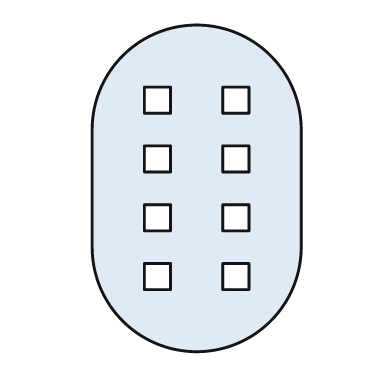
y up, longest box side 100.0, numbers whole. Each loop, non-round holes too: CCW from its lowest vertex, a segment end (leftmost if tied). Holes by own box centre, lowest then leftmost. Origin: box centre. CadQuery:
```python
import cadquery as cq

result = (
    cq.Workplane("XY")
    .moveTo(-32.0, -18.0)
    .threePointArc((0.0, -50.0), (32.0, -18.0))
    .lineTo(32.0, 18.0)
    .threePointArc((0.0, 50.0), (-32.0, 18.0))
    .close()
    .moveTo(-16.0, -31.0)
    .lineTo(-8.0, -31.0)
    .lineTo(-8.0, -23.0)
    .lineTo(-16.0, -23.0)
    .close()
    .moveTo(8.0, -31.0)
    .lineTo(16.0, -31.0)
    .lineTo(16.0, -23.0)
    .lineTo(8.0, -23.0)
    .close()
    .moveTo(-16.0, -13.0)
    .lineTo(-8.0, -13.0)
    .lineTo(-8.0, -5.0)
    .lineTo(-16.0, -5.0)
    .close()
    .moveTo(8.0, -13.0)
    .lineTo(16.0, -13.0)
    .lineTo(16.0, -5.0)
    .lineTo(8.0, -5.0)
    .close()
    .moveTo(-16.0, 5.0)
    .lineTo(-8.0, 5.0)
    .lineTo(-8.0, 13.0)
    .lineTo(-16.0, 13.0)
    .close()
    .moveTo(8.0, 5.0)
    .lineTo(16.0, 5.0)
    .lineTo(16.0, 13.0)
    .lineTo(8.0, 13.0)
    .close()
    .moveTo(-16.0, 23.0)
    .lineTo(-8.0, 23.0)
    .lineTo(-8.0, 31.0)
    .lineTo(-16.0, 31.0)
    .close()
    .moveTo(8.0, 23.0)
    .lineTo(16.0, 23.0)
    .lineTo(16.0, 31.0)
    .lineTo(8.0, 31.0)
    .close()
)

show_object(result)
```